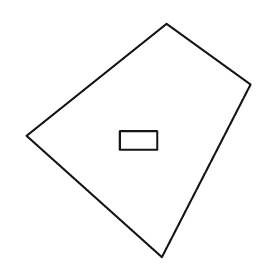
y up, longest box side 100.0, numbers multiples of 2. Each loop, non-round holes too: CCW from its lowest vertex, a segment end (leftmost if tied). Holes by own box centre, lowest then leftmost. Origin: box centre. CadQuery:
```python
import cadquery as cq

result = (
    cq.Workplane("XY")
    .moveTo(10.0, -50.0)
    .lineTo(48.0, 24.0)
    .lineTo(12.0, 50.0)
    .lineTo(-48.0, 2.0)
    .close()
    .moveTo(-8.0, -4.0)
    .lineTo(8.0, -4.0)
    .lineTo(8.0, 4.0)
    .lineTo(-8.0, 4.0)
    .close()
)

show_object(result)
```